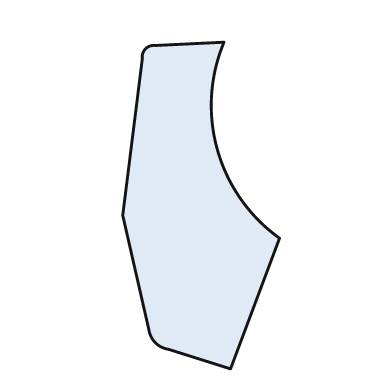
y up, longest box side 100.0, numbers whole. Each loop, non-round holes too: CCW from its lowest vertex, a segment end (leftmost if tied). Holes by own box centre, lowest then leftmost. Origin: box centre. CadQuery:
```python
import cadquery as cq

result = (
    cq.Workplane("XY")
    .moveTo(9.0, -50.0)
    .lineTo(24.0, -10.0)
    .threePointArc((5.0, 17.0), (7.0, 50.0))
    .lineTo(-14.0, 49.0)
    .threePointArc((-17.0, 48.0), (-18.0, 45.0))
    .lineTo(-24.0, -3.0)
    .lineTo(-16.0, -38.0)
    .threePointArc((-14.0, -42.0), (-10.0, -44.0))
    .close()
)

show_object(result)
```